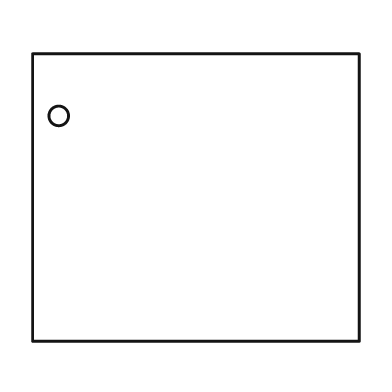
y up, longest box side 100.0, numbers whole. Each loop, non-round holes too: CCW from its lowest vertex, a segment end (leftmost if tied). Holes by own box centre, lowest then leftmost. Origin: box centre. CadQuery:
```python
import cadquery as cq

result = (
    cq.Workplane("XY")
    .moveTo(-50.0, -44.0)
    .lineTo(50.0, -44.0)
    .lineTo(50.0, 44.0)
    .lineTo(-50.0, 44.0)
    .close()
    .moveTo(-42.0, 25.0)
    .circle(3.0)
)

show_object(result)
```